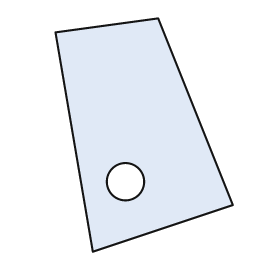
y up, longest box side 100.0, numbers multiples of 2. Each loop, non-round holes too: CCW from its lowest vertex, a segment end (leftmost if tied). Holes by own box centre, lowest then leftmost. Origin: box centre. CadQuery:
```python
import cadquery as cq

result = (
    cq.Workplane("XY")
    .moveTo(-22.0, -50.0)
    .lineTo(38.0, -30.0)
    .lineTo(6.0, 50.0)
    .lineTo(-38.0, 44.0)
    .close()
    .moveTo(-8.0, -20.0)
    .circle(8.0)
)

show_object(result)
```